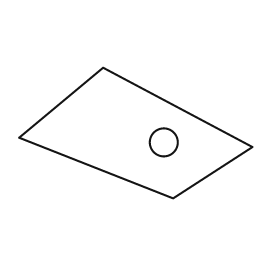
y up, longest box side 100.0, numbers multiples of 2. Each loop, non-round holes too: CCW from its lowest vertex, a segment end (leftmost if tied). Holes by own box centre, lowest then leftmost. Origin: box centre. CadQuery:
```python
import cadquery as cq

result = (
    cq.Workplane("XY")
    .moveTo(16.0, -28.0)
    .lineTo(50.0, -6.0)
    .lineTo(-14.0, 28.0)
    .lineTo(-50.0, -2.0)
    .close()
    .moveTo(12.0, -4.0)
    .circle(6.0)
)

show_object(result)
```